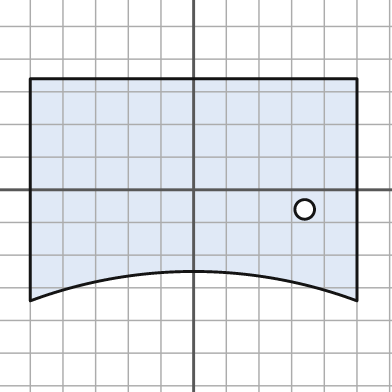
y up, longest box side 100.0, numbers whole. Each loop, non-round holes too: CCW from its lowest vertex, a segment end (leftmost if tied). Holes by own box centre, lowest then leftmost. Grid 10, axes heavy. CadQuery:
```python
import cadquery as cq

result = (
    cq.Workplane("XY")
    .moveTo(-50.0, -34.0)
    .threePointArc((0.0, -25.0), (50.0, -34.0))
    .lineTo(50.0, 34.0)
    .lineTo(-50.0, 34.0)
    .close()
    .moveTo(34.0, -6.0)
    .circle(3.0)
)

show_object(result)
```